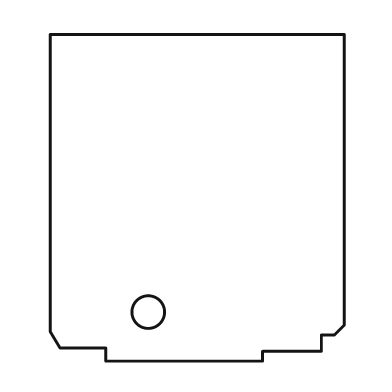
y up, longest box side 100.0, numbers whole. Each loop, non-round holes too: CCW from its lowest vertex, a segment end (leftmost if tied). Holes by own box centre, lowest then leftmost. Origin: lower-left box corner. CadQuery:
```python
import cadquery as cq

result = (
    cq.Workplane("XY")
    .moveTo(17.0, 0.0)
    .lineTo(65.0, 0.0)
    .lineTo(65.0, 3.0)
    .lineTo(83.0, 3.0)
    .lineTo(83.0, 8.0)
    .lineTo(87.0, 8.0)
    .lineTo(90.0, 11.0)
    .lineTo(90.0, 100.0)
    .lineTo(0.0, 100.0)
    .lineTo(0.0, 9.0)
    .lineTo(3.0, 4.0)
    .lineTo(17.0, 4.0)
    .close()
    .moveTo(30.0, 15.0)
    .circle(5.0)
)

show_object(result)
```